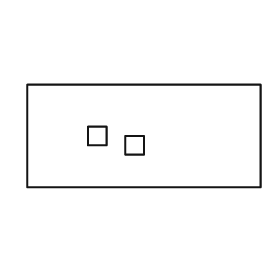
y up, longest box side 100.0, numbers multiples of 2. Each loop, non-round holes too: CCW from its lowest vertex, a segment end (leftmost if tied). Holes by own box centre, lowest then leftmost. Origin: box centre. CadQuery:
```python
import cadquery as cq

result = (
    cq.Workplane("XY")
    .moveTo(-50.0, -22.0)
    .lineTo(50.0, -22.0)
    .lineTo(50.0, 22.0)
    .lineTo(-50.0, 22.0)
    .close()
    .moveTo(-8.0, -8.0)
    .lineTo(0.0, -8.0)
    .lineTo(0.0, 0.0)
    .lineTo(-8.0, 0.0)
    .close()
    .moveTo(-24.0, -4.0)
    .lineTo(-16.0, -4.0)
    .lineTo(-16.0, 4.0)
    .lineTo(-24.0, 4.0)
    .close()
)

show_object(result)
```